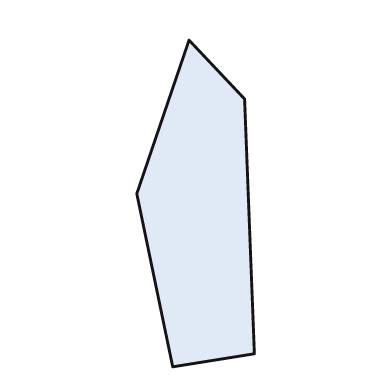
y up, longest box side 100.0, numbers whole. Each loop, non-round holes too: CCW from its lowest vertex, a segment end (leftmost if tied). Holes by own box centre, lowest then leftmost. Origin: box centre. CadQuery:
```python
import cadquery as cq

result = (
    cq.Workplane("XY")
    .moveTo(-7.0, -50.0)
    .lineTo(18.0, -46.0)
    .lineTo(15.0, 32.0)
    .lineTo(-2.0, 50.0)
    .lineTo(-18.0, 3.0)
    .close()
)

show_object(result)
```